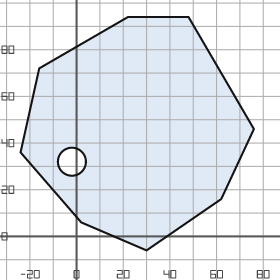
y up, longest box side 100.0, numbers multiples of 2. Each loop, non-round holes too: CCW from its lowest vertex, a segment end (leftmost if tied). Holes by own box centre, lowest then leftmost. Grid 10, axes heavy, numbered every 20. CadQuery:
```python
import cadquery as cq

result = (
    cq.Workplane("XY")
    .moveTo(30.0, -6.0)
    .lineTo(62.0, 16.0)
    .lineTo(76.0, 46.0)
    .lineTo(48.0, 94.0)
    .lineTo(22.0, 94.0)
    .lineTo(-16.0, 72.0)
    .lineTo(-24.0, 36.0)
    .lineTo(2.0, 6.0)
    .close()
    .moveTo(-2.0, 32.0)
    .circle(6.0)
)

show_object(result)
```